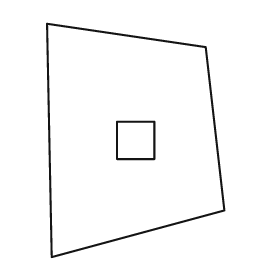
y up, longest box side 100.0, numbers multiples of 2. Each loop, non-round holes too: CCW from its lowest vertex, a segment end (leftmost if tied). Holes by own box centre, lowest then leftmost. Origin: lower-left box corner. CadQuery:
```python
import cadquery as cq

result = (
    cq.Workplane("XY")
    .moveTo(2.0, 0.0)
    .lineTo(76.0, 20.0)
    .lineTo(68.0, 90.0)
    .lineTo(0.0, 100.0)
    .close()
    .moveTo(30.0, 42.0)
    .lineTo(46.0, 42.0)
    .lineTo(46.0, 58.0)
    .lineTo(30.0, 58.0)
    .close()
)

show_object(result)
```